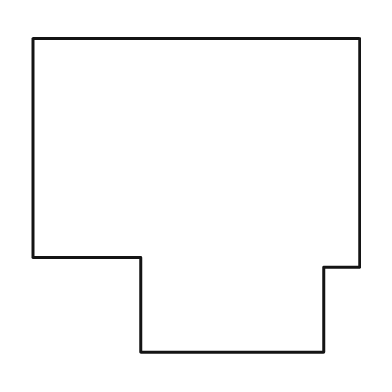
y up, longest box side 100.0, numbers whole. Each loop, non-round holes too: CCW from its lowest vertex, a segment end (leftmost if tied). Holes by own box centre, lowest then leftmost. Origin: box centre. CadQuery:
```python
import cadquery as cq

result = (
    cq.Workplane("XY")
    .moveTo(-17.0, -48.0)
    .lineTo(39.0, -48.0)
    .lineTo(39.0, -22.0)
    .lineTo(50.0, -22.0)
    .lineTo(50.0, 48.0)
    .lineTo(-50.0, 48.0)
    .lineTo(-50.0, -19.0)
    .lineTo(-17.0, -19.0)
    .close()
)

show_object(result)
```